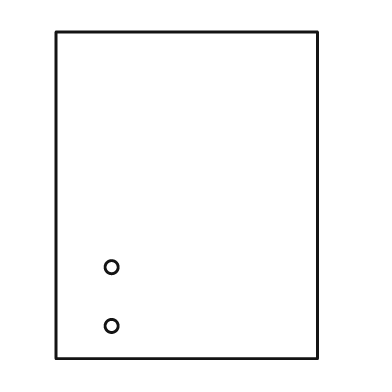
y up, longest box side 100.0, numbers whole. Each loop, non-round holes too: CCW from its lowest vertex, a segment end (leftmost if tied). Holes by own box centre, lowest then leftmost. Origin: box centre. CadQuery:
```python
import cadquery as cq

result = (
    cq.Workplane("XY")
    .moveTo(-40.0, -50.0)
    .lineTo(40.0, -50.0)
    .lineTo(40.0, 50.0)
    .lineTo(-40.0, 50.0)
    .close()
    .moveTo(-23.0, -40.0)
    .circle(2.0)
    .moveTo(-23.0, -22.0)
    .circle(2.0)
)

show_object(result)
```